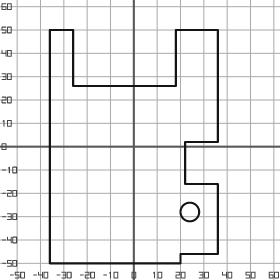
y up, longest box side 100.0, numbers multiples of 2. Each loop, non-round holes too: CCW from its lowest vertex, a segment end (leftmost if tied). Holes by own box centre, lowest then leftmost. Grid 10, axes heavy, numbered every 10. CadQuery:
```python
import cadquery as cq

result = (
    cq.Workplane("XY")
    .moveTo(-36.0, -50.0)
    .lineTo(20.0, -50.0)
    .lineTo(20.0, -46.0)
    .lineTo(36.0, -46.0)
    .lineTo(36.0, -16.0)
    .lineTo(22.0, -16.0)
    .lineTo(22.0, 2.0)
    .lineTo(36.0, 2.0)
    .lineTo(36.0, 50.0)
    .lineTo(18.0, 50.0)
    .lineTo(18.0, 26.0)
    .lineTo(-26.0, 26.0)
    .lineTo(-26.0, 50.0)
    .lineTo(-36.0, 50.0)
    .close()
    .moveTo(24.0, -28.0)
    .circle(4.0)
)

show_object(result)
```